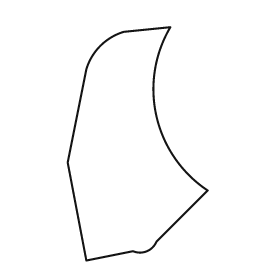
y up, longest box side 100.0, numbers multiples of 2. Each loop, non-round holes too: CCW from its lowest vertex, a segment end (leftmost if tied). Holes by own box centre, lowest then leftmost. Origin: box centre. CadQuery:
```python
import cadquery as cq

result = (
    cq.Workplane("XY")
    .moveTo(-22.0, -50.0)
    .lineTo(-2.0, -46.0)
    .threePointArc((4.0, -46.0), (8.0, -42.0))
    .lineTo(30.0, -20.0)
    .threePointArc((8.0, 12.0), (14.0, 50.0))
    .lineTo(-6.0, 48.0)
    .threePointArc((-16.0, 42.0), (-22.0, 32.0))
    .lineTo(-30.0, -8.0)
    .close()
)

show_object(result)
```